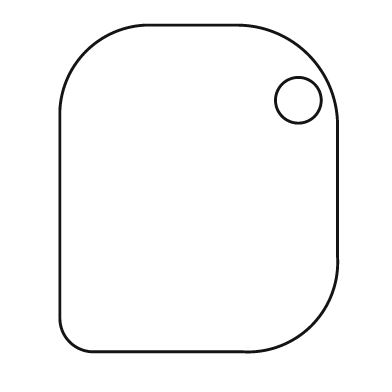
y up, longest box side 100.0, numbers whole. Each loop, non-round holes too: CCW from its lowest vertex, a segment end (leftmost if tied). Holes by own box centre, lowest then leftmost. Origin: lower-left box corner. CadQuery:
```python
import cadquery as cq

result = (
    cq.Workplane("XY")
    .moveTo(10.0, 0.0)
    .lineTo(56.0, 0.0)
    .threePointArc((77.0, 8.0), (85.0, 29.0))
    .lineTo(85.0, 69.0)
    .threePointArc((76.0, 91.0), (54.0, 100.0))
    .lineTo(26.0, 100.0)
    .threePointArc((8.0, 92.0), (0.0, 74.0))
    .lineTo(0.0, 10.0)
    .threePointArc((3.0, 3.0), (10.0, 0.0))
    .close()
    .moveTo(73.0, 77.0)
    .circle(7.0)
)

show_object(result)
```